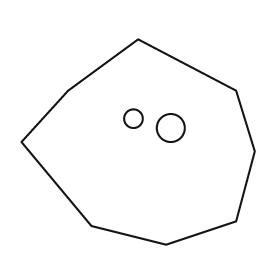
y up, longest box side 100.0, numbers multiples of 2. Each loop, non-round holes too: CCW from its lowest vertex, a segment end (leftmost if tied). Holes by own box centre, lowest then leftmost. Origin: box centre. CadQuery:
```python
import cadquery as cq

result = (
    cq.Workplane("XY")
    .moveTo(12.0, -44.0)
    .lineTo(42.0, -34.0)
    .lineTo(50.0, -4.0)
    .lineTo(42.0, 22.0)
    .lineTo(0.0, 44.0)
    .lineTo(-30.0, 22.0)
    .lineTo(-50.0, 0.0)
    .lineTo(-20.0, -36.0)
    .close()
    .moveTo(14.0, 6.0)
    .circle(6.0)
    .moveTo(-2.0, 10.0)
    .circle(4.0)
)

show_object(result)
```